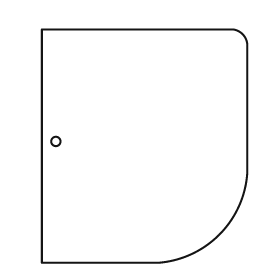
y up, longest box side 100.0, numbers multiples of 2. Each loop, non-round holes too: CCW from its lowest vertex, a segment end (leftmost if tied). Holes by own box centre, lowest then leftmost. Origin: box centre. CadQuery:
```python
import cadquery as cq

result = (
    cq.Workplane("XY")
    .moveTo(-44.0, -50.0)
    .lineTo(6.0, -50.0)
    .threePointArc((32.0, -38.0), (44.0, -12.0))
    .lineTo(44.0, 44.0)
    .threePointArc((42.0, 48.0), (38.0, 50.0))
    .lineTo(-44.0, 50.0)
    .close()
    .moveTo(-38.0, 2.0)
    .circle(2.0)
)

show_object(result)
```